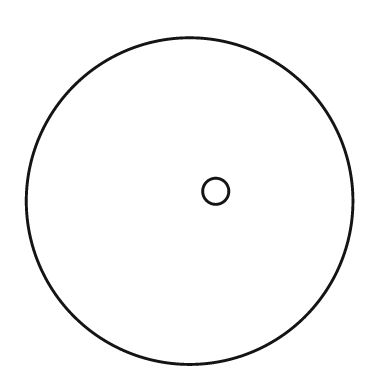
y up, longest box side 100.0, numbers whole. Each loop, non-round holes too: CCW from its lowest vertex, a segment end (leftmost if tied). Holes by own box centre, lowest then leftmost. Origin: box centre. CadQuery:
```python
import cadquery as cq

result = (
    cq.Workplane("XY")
    .moveTo(0.0, 0.0)
    .circle(50.0)
    .moveTo(8.0, 3.0)
    .circle(4.0)
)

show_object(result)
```